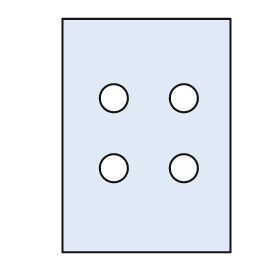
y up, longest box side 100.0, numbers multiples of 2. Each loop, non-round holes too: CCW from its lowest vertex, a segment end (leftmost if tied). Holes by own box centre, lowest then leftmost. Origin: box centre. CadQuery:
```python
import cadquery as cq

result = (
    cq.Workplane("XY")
    .moveTo(-36.0, -50.0)
    .lineTo(36.0, -50.0)
    .lineTo(36.0, 50.0)
    .lineTo(-36.0, 50.0)
    .close()
    .moveTo(-14.0, -14.0)
    .circle(6.0)
    .moveTo(16.0, -14.0)
    .circle(6.0)
    .moveTo(-14.0, 16.0)
    .circle(6.0)
    .moveTo(16.0, 16.0)
    .circle(6.0)
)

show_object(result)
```